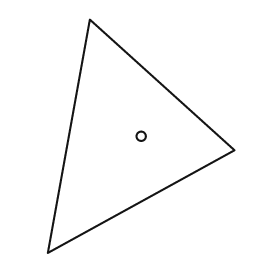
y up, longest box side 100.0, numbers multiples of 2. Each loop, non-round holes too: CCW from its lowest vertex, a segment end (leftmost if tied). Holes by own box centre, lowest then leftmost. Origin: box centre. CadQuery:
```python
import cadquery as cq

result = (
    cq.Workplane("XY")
    .moveTo(-40.0, -50.0)
    .lineTo(40.0, -6.0)
    .lineTo(-22.0, 50.0)
    .close()
    .moveTo(0.0, 0.0)
    .circle(2.0)
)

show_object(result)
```